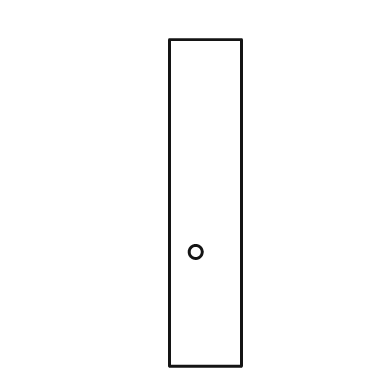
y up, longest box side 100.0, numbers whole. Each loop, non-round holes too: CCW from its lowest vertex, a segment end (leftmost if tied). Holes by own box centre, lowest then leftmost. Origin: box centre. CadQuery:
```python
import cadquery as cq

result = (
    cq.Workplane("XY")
    .moveTo(-11.0, -50.0)
    .lineTo(11.0, -50.0)
    .lineTo(11.0, 50.0)
    .lineTo(-11.0, 50.0)
    .close()
    .moveTo(-3.0, -15.0)
    .circle(2.0)
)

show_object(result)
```